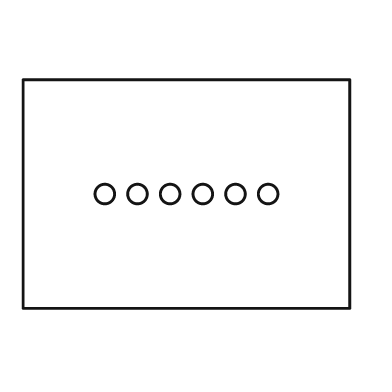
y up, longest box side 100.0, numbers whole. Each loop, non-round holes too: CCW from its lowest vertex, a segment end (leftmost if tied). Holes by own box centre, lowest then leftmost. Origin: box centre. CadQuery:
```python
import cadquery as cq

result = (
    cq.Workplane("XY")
    .moveTo(-50.0, -35.0)
    .lineTo(50.0, -35.0)
    .lineTo(50.0, 35.0)
    .lineTo(-50.0, 35.0)
    .close()
    .moveTo(-25.0, 0.0)
    .circle(3.0)
    .moveTo(-15.0, 0.0)
    .circle(3.0)
    .moveTo(-5.0, 0.0)
    .circle(3.0)
    .moveTo(5.0, 0.0)
    .circle(3.0)
    .moveTo(15.0, 0.0)
    .circle(3.0)
    .moveTo(25.0, 0.0)
    .circle(3.0)
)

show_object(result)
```